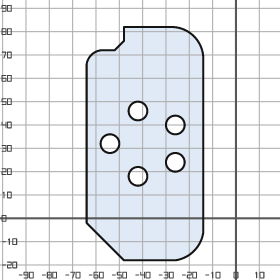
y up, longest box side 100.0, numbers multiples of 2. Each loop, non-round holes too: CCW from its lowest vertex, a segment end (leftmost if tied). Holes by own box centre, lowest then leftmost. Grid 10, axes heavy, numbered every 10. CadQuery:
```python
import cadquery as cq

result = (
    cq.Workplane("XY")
    .moveTo(-48.0, -18.0)
    .lineTo(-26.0, -18.0)
    .threePointArc((-18.0, -14.0), (-14.0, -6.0))
    .lineTo(-14.0, 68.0)
    .threePointArc((-18.0, 78.0), (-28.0, 82.0))
    .lineTo(-48.0, 82.0)
    .lineTo(-48.0, 76.0)
    .lineTo(-52.0, 72.0)
    .lineTo(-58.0, 72.0)
    .threePointArc((-62.0, 70.0), (-64.0, 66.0))
    .lineTo(-64.0, -2.0)
    .close()
    .moveTo(-42.0, 18.0)
    .circle(4.0)
    .moveTo(-26.0, 24.0)
    .circle(4.0)
    .moveTo(-54.0, 32.0)
    .circle(4.0)
    .moveTo(-26.0, 40.0)
    .circle(4.0)
    .moveTo(-42.0, 46.0)
    .circle(4.0)
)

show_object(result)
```